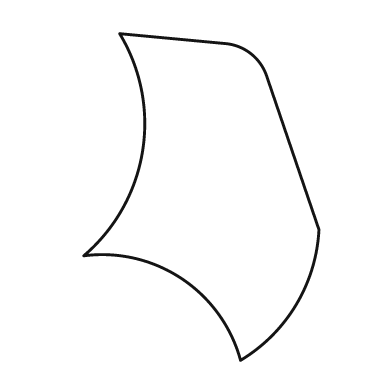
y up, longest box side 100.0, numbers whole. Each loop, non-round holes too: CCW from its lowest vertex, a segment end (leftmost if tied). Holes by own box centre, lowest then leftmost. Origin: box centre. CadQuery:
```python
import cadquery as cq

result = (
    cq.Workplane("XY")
    .moveTo(12.0, -50.0)
    .threePointArc((29.0, -33.0), (36.0, -10.0))
    .lineTo(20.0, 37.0)
    .threePointArc((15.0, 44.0), (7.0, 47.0))
    .lineTo(-25.0, 50.0)
    .threePointArc((-18.0, 14.0), (-36.0, -18.0))
    .threePointArc((-6.0, -25.0), (12.0, -50.0))
    .close()
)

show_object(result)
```